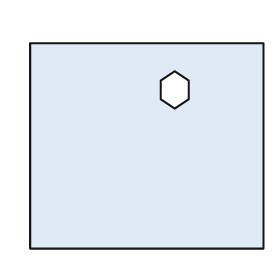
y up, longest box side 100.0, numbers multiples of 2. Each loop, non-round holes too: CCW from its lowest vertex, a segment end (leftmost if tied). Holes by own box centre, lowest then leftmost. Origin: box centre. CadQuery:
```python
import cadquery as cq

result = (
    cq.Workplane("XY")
    .moveTo(-50.0, -44.0)
    .lineTo(50.0, -44.0)
    .lineTo(50.0, 44.0)
    .lineTo(-50.0, 44.0)
    .close()
    .moveTo(12.0, 16.0)
    .lineTo(18.0, 20.0)
    .lineTo(18.0, 28.0)
    .lineTo(12.0, 32.0)
    .lineTo(6.0, 28.0)
    .lineTo(6.0, 20.0)
    .close()
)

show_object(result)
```